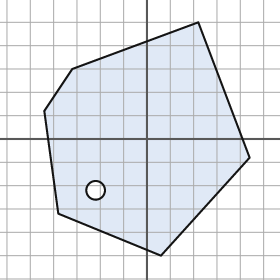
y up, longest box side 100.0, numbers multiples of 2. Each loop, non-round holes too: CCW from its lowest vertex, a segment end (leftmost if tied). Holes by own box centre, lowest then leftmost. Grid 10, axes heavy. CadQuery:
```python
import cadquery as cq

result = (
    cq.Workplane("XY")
    .moveTo(6.0, -50.0)
    .lineTo(44.0, -8.0)
    .lineTo(22.0, 50.0)
    .lineTo(-32.0, 30.0)
    .lineTo(-44.0, 12.0)
    .lineTo(-38.0, -32.0)
    .close()
    .moveTo(-22.0, -22.0)
    .circle(4.0)
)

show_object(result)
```